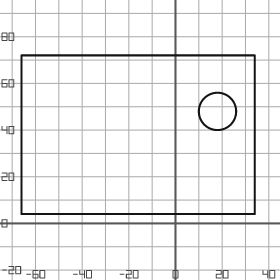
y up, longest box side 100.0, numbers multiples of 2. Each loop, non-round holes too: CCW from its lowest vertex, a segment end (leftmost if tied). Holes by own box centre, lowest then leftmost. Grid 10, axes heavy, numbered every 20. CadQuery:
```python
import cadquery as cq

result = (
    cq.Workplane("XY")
    .moveTo(-66.0, 4.0)
    .lineTo(34.0, 4.0)
    .lineTo(34.0, 72.0)
    .lineTo(-66.0, 72.0)
    .close()
    .moveTo(18.0, 48.0)
    .circle(8.0)
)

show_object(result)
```